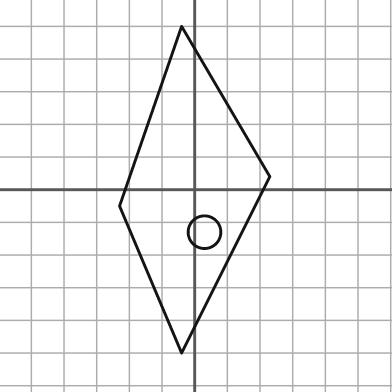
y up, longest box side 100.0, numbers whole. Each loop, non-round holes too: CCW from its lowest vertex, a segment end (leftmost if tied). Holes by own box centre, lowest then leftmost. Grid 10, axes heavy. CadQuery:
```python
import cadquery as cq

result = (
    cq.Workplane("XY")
    .moveTo(-4.0, -50.0)
    .lineTo(23.0, 4.0)
    .lineTo(-4.0, 50.0)
    .lineTo(-23.0, -5.0)
    .close()
    .moveTo(3.0, -13.0)
    .circle(5.0)
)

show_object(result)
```